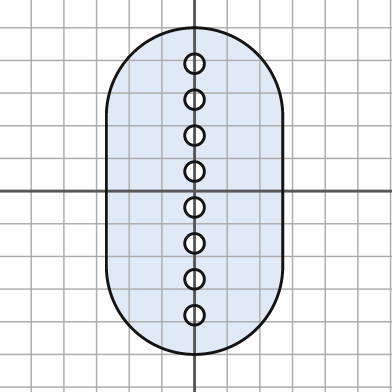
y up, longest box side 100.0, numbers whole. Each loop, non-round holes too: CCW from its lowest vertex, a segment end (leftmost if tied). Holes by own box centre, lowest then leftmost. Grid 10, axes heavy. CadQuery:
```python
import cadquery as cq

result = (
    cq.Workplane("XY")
    .moveTo(-27.0, -23.0)
    .threePointArc((0.0, -50.0), (27.0, -23.0))
    .lineTo(27.0, 23.0)
    .threePointArc((0.0, 50.0), (-27.0, 23.0))
    .close()
    .moveTo(0.0, -38.0)
    .circle(3.0)
    .moveTo(0.0, -27.0)
    .circle(3.0)
    .moveTo(0.0, -16.0)
    .circle(3.0)
    .moveTo(0.0, -5.0)
    .circle(3.0)
    .moveTo(0.0, 6.0)
    .circle(3.0)
    .moveTo(0.0, 17.0)
    .circle(3.0)
    .moveTo(0.0, 28.0)
    .circle(3.0)
    .moveTo(0.0, 39.0)
    .circle(3.0)
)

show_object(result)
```